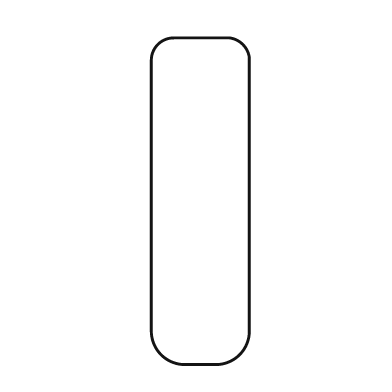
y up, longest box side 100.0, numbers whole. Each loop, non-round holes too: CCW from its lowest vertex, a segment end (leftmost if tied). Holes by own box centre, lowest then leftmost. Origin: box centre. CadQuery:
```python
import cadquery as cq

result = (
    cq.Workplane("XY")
    .moveTo(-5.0, -50.0)
    .lineTo(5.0, -50.0)
    .threePointArc((12.0, -47.0), (15.0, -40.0))
    .lineTo(15.0, 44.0)
    .threePointArc((13.0, 48.0), (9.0, 50.0))
    .lineTo(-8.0, 50.0)
    .threePointArc((-13.0, 48.0), (-15.0, 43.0))
    .lineTo(-15.0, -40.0)
    .threePointArc((-12.0, -47.0), (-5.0, -50.0))
    .close()
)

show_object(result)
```